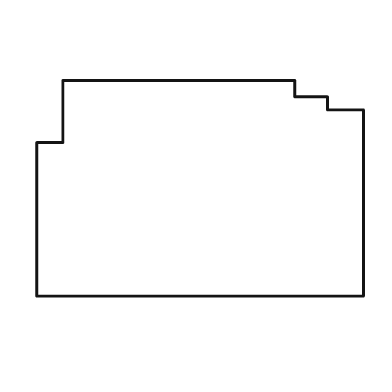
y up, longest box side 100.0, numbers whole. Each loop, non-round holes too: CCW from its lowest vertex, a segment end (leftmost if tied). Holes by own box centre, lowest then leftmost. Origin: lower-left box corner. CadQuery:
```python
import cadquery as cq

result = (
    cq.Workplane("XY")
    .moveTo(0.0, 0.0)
    .lineTo(100.0, 0.0)
    .lineTo(100.0, 57.0)
    .lineTo(89.0, 57.0)
    .lineTo(89.0, 61.0)
    .lineTo(79.0, 61.0)
    .lineTo(79.0, 66.0)
    .lineTo(8.0, 66.0)
    .lineTo(8.0, 47.0)
    .lineTo(0.0, 47.0)
    .close()
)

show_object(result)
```